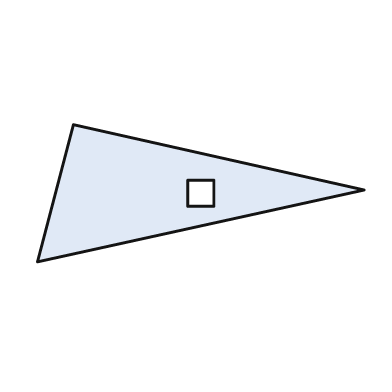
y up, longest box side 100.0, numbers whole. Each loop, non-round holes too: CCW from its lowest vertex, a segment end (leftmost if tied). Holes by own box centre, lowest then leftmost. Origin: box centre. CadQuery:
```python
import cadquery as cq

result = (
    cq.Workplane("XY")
    .moveTo(-50.0, -21.0)
    .lineTo(50.0, 1.0)
    .lineTo(-39.0, 21.0)
    .close()
    .moveTo(-4.0, -4.0)
    .lineTo(4.0, -4.0)
    .lineTo(4.0, 4.0)
    .lineTo(-4.0, 4.0)
    .close()
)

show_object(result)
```